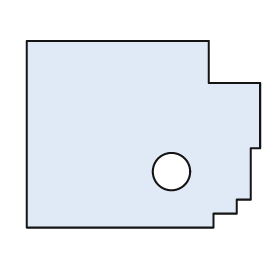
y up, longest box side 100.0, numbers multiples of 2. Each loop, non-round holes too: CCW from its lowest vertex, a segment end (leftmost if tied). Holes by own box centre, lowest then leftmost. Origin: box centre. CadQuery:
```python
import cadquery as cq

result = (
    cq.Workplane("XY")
    .moveTo(-50.0, -40.0)
    .lineTo(30.0, -40.0)
    .lineTo(30.0, -34.0)
    .lineTo(40.0, -34.0)
    .lineTo(40.0, -28.0)
    .lineTo(46.0, -28.0)
    .lineTo(46.0, -6.0)
    .lineTo(50.0, -6.0)
    .lineTo(50.0, 22.0)
    .lineTo(28.0, 22.0)
    .lineTo(28.0, 40.0)
    .lineTo(-50.0, 40.0)
    .close()
    .moveTo(12.0, -16.0)
    .circle(8.0)
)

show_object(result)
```